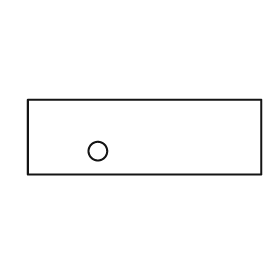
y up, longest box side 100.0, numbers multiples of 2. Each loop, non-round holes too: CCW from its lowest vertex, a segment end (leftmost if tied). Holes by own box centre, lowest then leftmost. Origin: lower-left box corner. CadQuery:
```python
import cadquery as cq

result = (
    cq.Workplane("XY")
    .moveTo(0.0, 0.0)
    .lineTo(100.0, 0.0)
    .lineTo(100.0, 32.0)
    .lineTo(0.0, 32.0)
    .close()
    .moveTo(30.0, 10.0)
    .circle(4.0)
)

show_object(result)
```